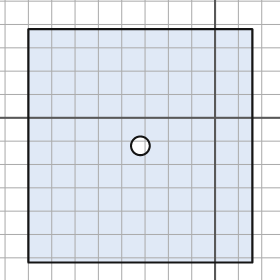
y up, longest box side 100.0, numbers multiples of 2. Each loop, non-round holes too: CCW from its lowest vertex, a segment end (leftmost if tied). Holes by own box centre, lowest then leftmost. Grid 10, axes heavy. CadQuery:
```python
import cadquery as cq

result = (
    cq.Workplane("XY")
    .moveTo(-80.0, -62.0)
    .lineTo(16.0, -62.0)
    .lineTo(16.0, 38.0)
    .lineTo(-80.0, 38.0)
    .close()
    .moveTo(-32.0, -12.0)
    .circle(4.0)
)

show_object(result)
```